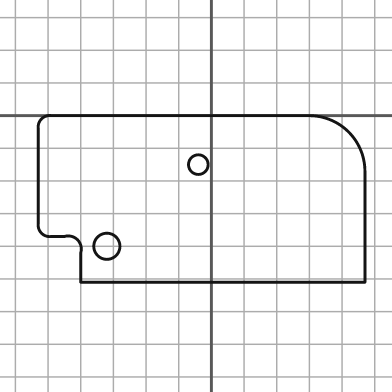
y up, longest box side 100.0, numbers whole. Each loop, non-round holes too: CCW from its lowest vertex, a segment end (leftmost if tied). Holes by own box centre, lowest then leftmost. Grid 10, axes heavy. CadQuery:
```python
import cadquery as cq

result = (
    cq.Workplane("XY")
    .moveTo(-40.0, -51.0)
    .lineTo(47.0, -51.0)
    .lineTo(47.0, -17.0)
    .threePointArc((42.0, -5.0), (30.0, 0.0))
    .lineTo(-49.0, 0.0)
    .threePointArc((-52.0, -1.0), (-53.0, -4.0))
    .lineTo(-53.0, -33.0)
    .threePointArc((-52.0, -36.0), (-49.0, -37.0))
    .lineTo(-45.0, -37.0)
    .threePointArc((-41.0, -38.0), (-40.0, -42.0))
    .close()
    .moveTo(-32.0, -40.0)
    .circle(4.0)
    .moveTo(-4.0, -15.0)
    .circle(3.0)
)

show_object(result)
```